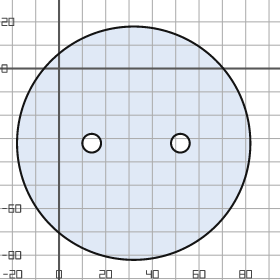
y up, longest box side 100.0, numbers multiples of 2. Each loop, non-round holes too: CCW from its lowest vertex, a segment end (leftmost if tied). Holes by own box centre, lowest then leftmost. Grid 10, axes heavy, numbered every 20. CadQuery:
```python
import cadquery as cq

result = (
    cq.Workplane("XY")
    .moveTo(32.0, -32.0)
    .circle(50.0)
    .moveTo(14.0, -32.0)
    .circle(4.0)
    .moveTo(52.0, -32.0)
    .circle(4.0)
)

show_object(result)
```